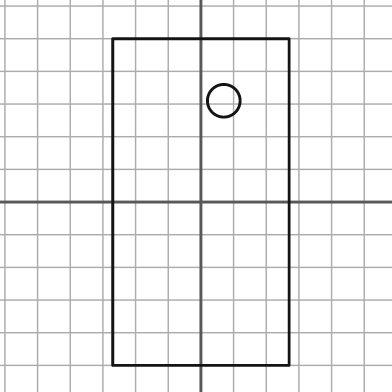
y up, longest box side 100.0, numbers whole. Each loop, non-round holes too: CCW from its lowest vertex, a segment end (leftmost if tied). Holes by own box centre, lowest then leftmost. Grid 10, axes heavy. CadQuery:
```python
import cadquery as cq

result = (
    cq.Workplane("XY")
    .moveTo(-27.0, -50.0)
    .lineTo(27.0, -50.0)
    .lineTo(27.0, 50.0)
    .lineTo(-27.0, 50.0)
    .close()
    .moveTo(7.0, 31.0)
    .circle(5.0)
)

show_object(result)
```